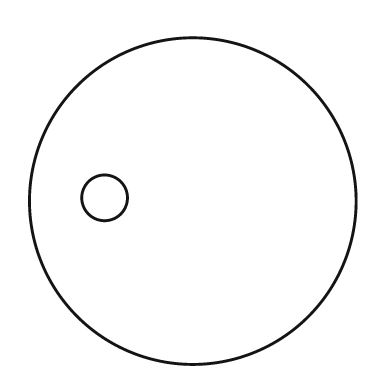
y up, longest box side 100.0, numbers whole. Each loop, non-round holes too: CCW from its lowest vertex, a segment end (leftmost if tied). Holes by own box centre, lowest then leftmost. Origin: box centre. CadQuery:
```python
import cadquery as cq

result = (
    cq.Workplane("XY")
    .moveTo(0.0, 0.0)
    .circle(50.0)
    .moveTo(-27.0, 1.0)
    .circle(7.0)
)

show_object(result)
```